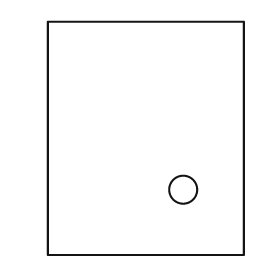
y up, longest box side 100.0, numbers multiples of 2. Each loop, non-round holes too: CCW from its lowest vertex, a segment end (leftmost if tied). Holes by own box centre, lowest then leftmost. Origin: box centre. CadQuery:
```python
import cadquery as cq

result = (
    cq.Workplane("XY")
    .moveTo(-42.0, -50.0)
    .lineTo(42.0, -50.0)
    .lineTo(42.0, 50.0)
    .lineTo(-42.0, 50.0)
    .close()
    .moveTo(16.0, -22.0)
    .circle(6.0)
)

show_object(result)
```